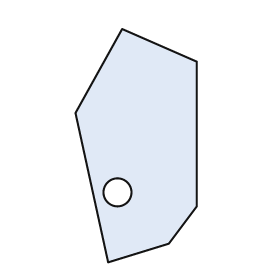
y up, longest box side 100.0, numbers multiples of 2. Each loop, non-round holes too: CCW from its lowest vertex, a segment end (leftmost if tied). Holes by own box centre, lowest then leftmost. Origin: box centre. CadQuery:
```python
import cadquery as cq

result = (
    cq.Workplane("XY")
    .moveTo(-12.0, -50.0)
    .lineTo(14.0, -42.0)
    .lineTo(26.0, -26.0)
    .lineTo(26.0, 36.0)
    .lineTo(-6.0, 50.0)
    .lineTo(-26.0, 14.0)
    .close()
    .moveTo(-8.0, -20.0)
    .circle(6.0)
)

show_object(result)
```